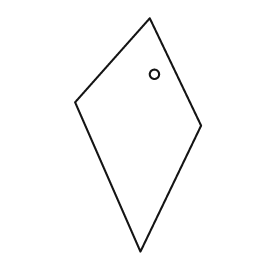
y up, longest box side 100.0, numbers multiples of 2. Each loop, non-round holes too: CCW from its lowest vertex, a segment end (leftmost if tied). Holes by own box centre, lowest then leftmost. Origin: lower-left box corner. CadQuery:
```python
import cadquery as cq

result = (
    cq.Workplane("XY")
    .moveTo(28.0, 0.0)
    .lineTo(54.0, 54.0)
    .lineTo(32.0, 100.0)
    .lineTo(0.0, 64.0)
    .close()
    .moveTo(34.0, 76.0)
    .circle(2.0)
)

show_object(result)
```